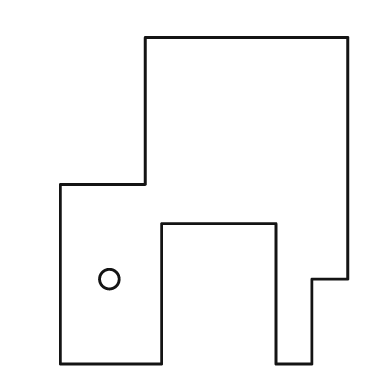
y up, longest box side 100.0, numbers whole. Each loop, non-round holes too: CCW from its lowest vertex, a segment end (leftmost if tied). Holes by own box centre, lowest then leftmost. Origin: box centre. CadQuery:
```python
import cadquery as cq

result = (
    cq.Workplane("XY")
    .moveTo(-44.0, -50.0)
    .lineTo(-13.0, -50.0)
    .lineTo(-13.0, -7.0)
    .lineTo(22.0, -7.0)
    .lineTo(22.0, -50.0)
    .lineTo(33.0, -50.0)
    .lineTo(33.0, -24.0)
    .lineTo(44.0, -24.0)
    .lineTo(44.0, 50.0)
    .lineTo(-18.0, 50.0)
    .lineTo(-18.0, 5.0)
    .lineTo(-44.0, 5.0)
    .close()
    .moveTo(-29.0, -24.0)
    .circle(3.0)
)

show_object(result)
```